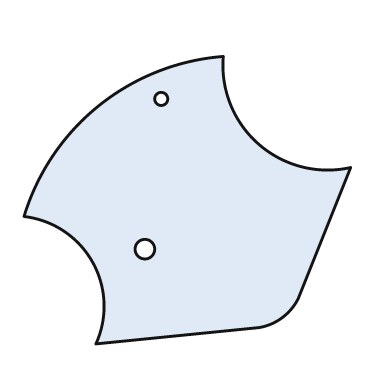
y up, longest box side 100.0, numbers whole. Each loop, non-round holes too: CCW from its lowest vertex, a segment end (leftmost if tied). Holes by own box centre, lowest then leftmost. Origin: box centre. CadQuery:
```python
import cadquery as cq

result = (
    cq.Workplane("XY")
    .moveTo(-28.0, -44.0)
    .lineTo(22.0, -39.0)
    .threePointArc((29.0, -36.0), (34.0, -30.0))
    .lineTo(50.0, 10.0)
    .threePointArc((22.0, 17.0), (11.0, 44.0))
    .threePointArc((-27.0, 29.0), (-50.0, -5.0))
    .threePointArc((-29.0, -19.0), (-28.0, -44.0))
    .close()
    .moveTo(-13.0, -15.0)
    .circle(3.0)
    .moveTo(-8.0, 31.0)
    .circle(2.0)
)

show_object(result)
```